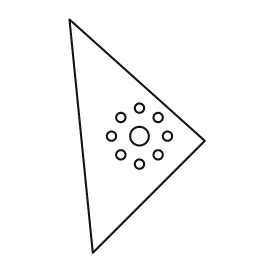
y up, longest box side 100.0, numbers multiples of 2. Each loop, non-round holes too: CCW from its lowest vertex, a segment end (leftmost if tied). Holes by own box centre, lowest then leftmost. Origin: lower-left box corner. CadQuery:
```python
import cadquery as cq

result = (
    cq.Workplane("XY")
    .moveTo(10.0, 0.0)
    .lineTo(58.0, 48.0)
    .lineTo(0.0, 100.0)
    .close()
    .moveTo(30.0, 38.0)
    .circle(2.0)
    .moveTo(22.0, 42.0)
    .circle(2.0)
    .moveTo(38.0, 42.0)
    .circle(2.0)
    .moveTo(18.0, 50.0)
    .circle(2.0)
    .moveTo(30.0, 50.0)
    .circle(4.0)
    .moveTo(42.0, 50.0)
    .circle(2.0)
    .moveTo(22.0, 58.0)
    .circle(2.0)
    .moveTo(38.0, 58.0)
    .circle(2.0)
    .moveTo(30.0, 62.0)
    .circle(2.0)
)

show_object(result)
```